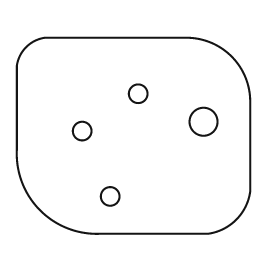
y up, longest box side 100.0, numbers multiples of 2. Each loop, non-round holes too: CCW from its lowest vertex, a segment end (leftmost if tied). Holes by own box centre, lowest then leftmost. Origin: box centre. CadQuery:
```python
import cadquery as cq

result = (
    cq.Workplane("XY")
    .moveTo(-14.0, -42.0)
    .lineTo(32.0, -42.0)
    .threePointArc((44.0, -36.0), (50.0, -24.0))
    .lineTo(50.0, 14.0)
    .threePointArc((42.0, 34.0), (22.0, 42.0))
    .lineTo(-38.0, 42.0)
    .threePointArc((-46.0, 38.0), (-50.0, 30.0))
    .lineTo(-50.0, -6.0)
    .threePointArc((-40.0, -32.0), (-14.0, -42.0))
    .close()
    .moveTo(-10.0, -26.0)
    .circle(4.0)
    .moveTo(-22.0, 2.0)
    .circle(4.0)
    .moveTo(30.0, 6.0)
    .circle(6.0)
    .moveTo(2.0, 18.0)
    .circle(4.0)
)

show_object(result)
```